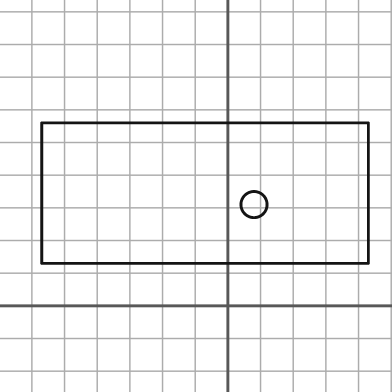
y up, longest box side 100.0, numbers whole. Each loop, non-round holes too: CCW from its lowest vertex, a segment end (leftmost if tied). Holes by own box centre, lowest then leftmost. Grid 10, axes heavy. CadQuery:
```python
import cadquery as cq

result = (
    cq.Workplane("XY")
    .moveTo(-57.0, 13.0)
    .lineTo(43.0, 13.0)
    .lineTo(43.0, 56.0)
    .lineTo(-57.0, 56.0)
    .close()
    .moveTo(8.0, 31.0)
    .circle(4.0)
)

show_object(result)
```